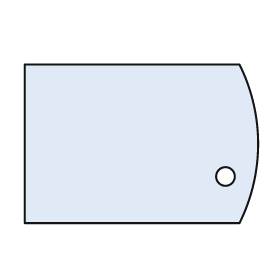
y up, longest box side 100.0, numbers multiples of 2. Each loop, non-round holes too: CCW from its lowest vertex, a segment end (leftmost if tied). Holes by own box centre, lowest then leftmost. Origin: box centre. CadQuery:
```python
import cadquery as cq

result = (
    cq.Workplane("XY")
    .moveTo(-50.0, -34.0)
    .lineTo(42.0, -34.0)
    .threePointArc((50.0, 0.0), (42.0, 34.0))
    .lineTo(-50.0, 34.0)
    .close()
    .moveTo(36.0, -14.0)
    .circle(4.0)
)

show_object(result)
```